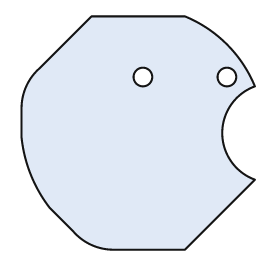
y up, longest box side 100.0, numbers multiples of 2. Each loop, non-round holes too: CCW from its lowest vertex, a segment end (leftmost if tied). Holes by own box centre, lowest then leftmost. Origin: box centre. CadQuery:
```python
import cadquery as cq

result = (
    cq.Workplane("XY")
    .moveTo(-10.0, -50.0)
    .lineTo(20.0, -50.0)
    .lineTo(50.0, -20.0)
    .threePointArc((36.0, 0.0), (50.0, 20.0))
    .threePointArc((38.0, 38.0), (20.0, 50.0))
    .lineTo(-20.0, 50.0)
    .lineTo(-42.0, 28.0)
    .threePointArc((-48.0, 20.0), (-50.0, 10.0))
    .lineTo(-50.0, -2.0)
    .threePointArc((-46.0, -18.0), (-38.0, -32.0))
    .lineTo(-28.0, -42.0)
    .threePointArc((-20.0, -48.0), (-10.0, -50.0))
    .close()
    .moveTo(2.0, 24.0)
    .circle(4.0)
    .moveTo(38.0, 24.0)
    .circle(4.0)
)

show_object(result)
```